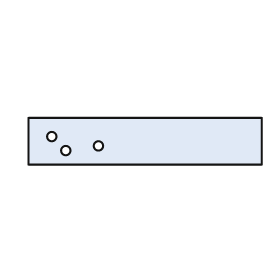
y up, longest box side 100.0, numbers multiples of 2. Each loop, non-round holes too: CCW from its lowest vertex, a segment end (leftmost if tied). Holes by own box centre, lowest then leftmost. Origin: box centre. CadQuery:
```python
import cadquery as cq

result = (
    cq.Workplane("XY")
    .moveTo(-50.0, -10.0)
    .lineTo(50.0, -10.0)
    .lineTo(50.0, 10.0)
    .lineTo(-50.0, 10.0)
    .close()
    .moveTo(-34.0, -4.0)
    .circle(2.0)
    .moveTo(-20.0, -2.0)
    .circle(2.0)
    .moveTo(-40.0, 2.0)
    .circle(2.0)
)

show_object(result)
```